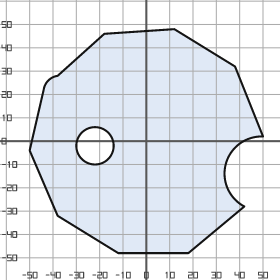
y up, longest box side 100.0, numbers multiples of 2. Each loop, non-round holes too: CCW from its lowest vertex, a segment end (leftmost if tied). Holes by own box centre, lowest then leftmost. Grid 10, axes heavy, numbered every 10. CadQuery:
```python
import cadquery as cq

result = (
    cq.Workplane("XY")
    .moveTo(-12.0, -48.0)
    .lineTo(18.0, -48.0)
    .lineTo(42.0, -28.0)
    .threePointArc((34.0, -10.0), (50.0, 2.0))
    .lineTo(38.0, 32.0)
    .lineTo(12.0, 48.0)
    .lineTo(-18.0, 46.0)
    .lineTo(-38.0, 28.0)
    .threePointArc((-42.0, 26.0), (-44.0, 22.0))
    .lineTo(-50.0, -4.0)
    .lineTo(-38.0, -32.0)
    .close()
    .moveTo(-22.0, -2.0)
    .circle(8.0)
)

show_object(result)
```